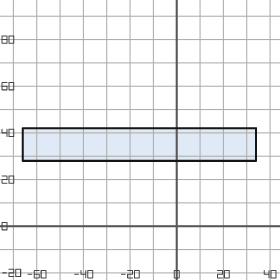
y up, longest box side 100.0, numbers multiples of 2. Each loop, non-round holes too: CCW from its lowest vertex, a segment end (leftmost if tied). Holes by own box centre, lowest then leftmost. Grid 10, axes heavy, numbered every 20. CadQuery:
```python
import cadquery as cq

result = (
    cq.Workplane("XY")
    .moveTo(-66.0, 28.0)
    .lineTo(34.0, 28.0)
    .lineTo(34.0, 42.0)
    .lineTo(-66.0, 42.0)
    .close()
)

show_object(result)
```